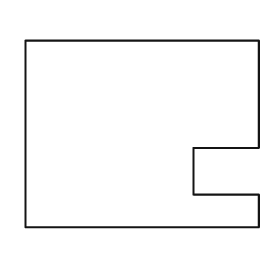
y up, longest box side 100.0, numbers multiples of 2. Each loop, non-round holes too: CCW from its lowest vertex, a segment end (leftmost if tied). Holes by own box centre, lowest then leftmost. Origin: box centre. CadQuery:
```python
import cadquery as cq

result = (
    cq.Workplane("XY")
    .moveTo(-50.0, -40.0)
    .lineTo(50.0, -40.0)
    .lineTo(50.0, -26.0)
    .lineTo(22.0, -26.0)
    .lineTo(22.0, -6.0)
    .lineTo(50.0, -6.0)
    .lineTo(50.0, 40.0)
    .lineTo(-50.0, 40.0)
    .close()
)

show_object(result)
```